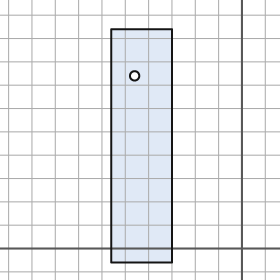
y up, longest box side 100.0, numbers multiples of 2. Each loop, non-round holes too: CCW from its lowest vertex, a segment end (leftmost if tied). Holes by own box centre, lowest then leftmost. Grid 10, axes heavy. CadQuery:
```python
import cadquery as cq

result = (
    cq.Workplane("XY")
    .moveTo(-56.0, -6.0)
    .lineTo(-30.0, -6.0)
    .lineTo(-30.0, 94.0)
    .lineTo(-56.0, 94.0)
    .close()
    .moveTo(-46.0, 74.0)
    .circle(2.0)
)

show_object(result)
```